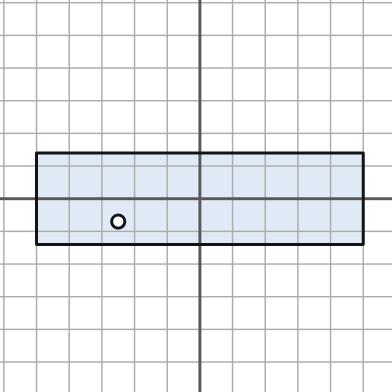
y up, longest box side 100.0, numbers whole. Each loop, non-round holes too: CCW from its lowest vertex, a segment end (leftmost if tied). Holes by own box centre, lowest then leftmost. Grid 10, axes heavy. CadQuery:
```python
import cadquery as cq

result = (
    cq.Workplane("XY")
    .moveTo(-50.0, -14.0)
    .lineTo(50.0, -14.0)
    .lineTo(50.0, 14.0)
    .lineTo(-50.0, 14.0)
    .close()
    .moveTo(-25.0, -7.0)
    .circle(2.0)
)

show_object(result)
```